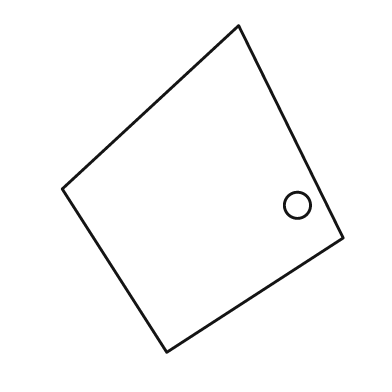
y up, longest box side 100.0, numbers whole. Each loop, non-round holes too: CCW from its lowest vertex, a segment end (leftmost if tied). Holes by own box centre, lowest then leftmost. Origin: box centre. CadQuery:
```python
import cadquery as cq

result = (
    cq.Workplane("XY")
    .moveTo(-11.0, -50.0)
    .lineTo(43.0, -15.0)
    .lineTo(11.0, 50.0)
    .lineTo(-43.0, 0.0)
    .close()
    .moveTo(29.0, -5.0)
    .circle(4.0)
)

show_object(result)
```